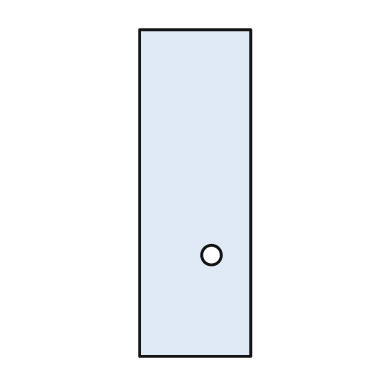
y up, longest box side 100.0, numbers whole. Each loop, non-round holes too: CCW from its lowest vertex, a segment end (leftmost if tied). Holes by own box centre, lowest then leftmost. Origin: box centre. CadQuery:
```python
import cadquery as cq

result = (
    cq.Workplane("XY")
    .moveTo(-17.0, -50.0)
    .lineTo(17.0, -50.0)
    .lineTo(17.0, 50.0)
    .lineTo(-17.0, 50.0)
    .close()
    .moveTo(5.0, -19.0)
    .circle(3.0)
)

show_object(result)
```